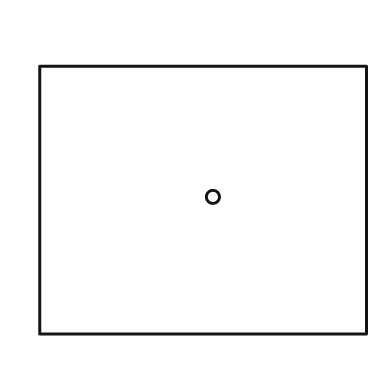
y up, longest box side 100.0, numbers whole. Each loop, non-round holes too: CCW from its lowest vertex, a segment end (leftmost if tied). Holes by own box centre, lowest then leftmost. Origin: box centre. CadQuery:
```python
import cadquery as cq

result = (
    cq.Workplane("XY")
    .moveTo(-50.0, -41.0)
    .lineTo(50.0, -41.0)
    .lineTo(50.0, 41.0)
    .lineTo(-50.0, 41.0)
    .close()
    .moveTo(3.0, 1.0)
    .circle(2.0)
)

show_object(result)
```